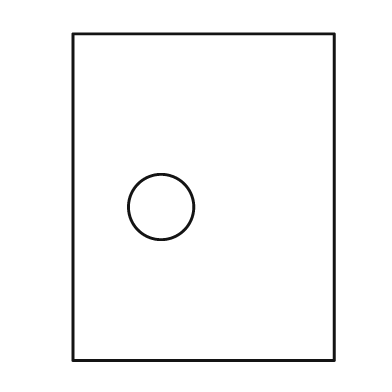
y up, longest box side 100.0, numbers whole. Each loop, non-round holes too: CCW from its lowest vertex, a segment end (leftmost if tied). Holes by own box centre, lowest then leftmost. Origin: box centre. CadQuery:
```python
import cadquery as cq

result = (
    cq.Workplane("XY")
    .moveTo(-40.0, -50.0)
    .lineTo(40.0, -50.0)
    .lineTo(40.0, 50.0)
    .lineTo(-40.0, 50.0)
    .close()
    .moveTo(-13.0, -3.0)
    .circle(10.0)
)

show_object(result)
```